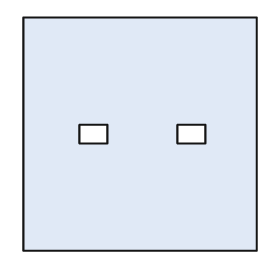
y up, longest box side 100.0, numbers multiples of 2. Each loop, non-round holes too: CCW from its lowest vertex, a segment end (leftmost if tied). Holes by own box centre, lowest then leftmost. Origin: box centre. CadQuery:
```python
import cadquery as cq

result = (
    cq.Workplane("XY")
    .moveTo(-50.0, -50.0)
    .lineTo(50.0, -50.0)
    .lineTo(50.0, 50.0)
    .lineTo(-50.0, 50.0)
    .close()
    .moveTo(-26.0, -4.0)
    .lineTo(-14.0, -4.0)
    .lineTo(-14.0, 4.0)
    .lineTo(-26.0, 4.0)
    .close()
    .moveTo(16.0, -4.0)
    .lineTo(28.0, -4.0)
    .lineTo(28.0, 4.0)
    .lineTo(16.0, 4.0)
    .close()
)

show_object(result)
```